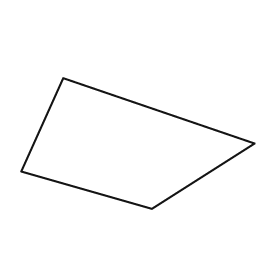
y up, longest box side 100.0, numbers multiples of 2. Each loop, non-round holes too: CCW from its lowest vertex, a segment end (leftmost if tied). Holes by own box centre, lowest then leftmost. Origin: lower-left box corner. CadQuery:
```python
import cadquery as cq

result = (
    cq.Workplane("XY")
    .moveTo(56.0, 0.0)
    .lineTo(100.0, 28.0)
    .lineTo(18.0, 56.0)
    .lineTo(0.0, 16.0)
    .close()
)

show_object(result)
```